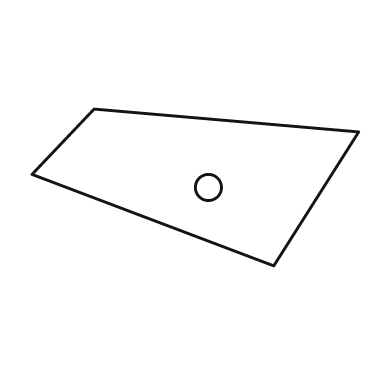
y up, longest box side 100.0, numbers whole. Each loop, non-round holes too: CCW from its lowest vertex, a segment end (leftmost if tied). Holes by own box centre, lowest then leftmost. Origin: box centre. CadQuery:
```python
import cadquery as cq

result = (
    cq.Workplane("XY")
    .moveTo(24.0, -24.0)
    .lineTo(50.0, 17.0)
    .lineTo(-31.0, 24.0)
    .lineTo(-50.0, 4.0)
    .close()
    .moveTo(4.0, 0.0)
    .circle(4.0)
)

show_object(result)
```